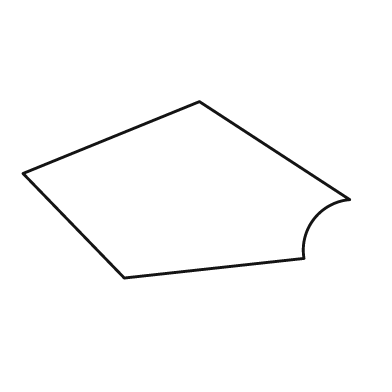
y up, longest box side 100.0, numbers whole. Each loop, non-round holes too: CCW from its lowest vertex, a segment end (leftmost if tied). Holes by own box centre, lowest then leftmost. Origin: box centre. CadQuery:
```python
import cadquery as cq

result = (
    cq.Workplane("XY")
    .moveTo(-19.0, -27.0)
    .lineTo(36.0, -21.0)
    .threePointArc((39.0, -9.0), (50.0, -3.0))
    .lineTo(4.0, 27.0)
    .lineTo(-50.0, 5.0)
    .close()
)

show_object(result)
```